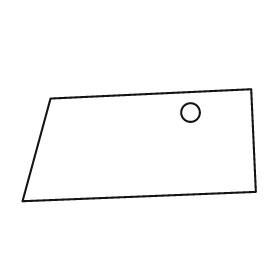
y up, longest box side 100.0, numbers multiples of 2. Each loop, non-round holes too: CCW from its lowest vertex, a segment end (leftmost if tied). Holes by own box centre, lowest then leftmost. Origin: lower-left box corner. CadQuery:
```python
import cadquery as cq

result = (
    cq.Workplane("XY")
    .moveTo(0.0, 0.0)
    .lineTo(100.0, 4.0)
    .lineTo(98.0, 48.0)
    .lineTo(12.0, 44.0)
    .close()
    .moveTo(72.0, 38.0)
    .circle(4.0)
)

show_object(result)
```